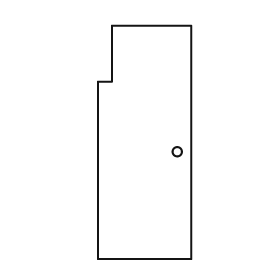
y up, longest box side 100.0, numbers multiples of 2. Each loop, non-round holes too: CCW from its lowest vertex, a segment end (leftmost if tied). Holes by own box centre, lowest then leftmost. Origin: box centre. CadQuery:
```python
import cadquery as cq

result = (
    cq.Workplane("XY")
    .moveTo(-20.0, -50.0)
    .lineTo(20.0, -50.0)
    .lineTo(20.0, 50.0)
    .lineTo(-14.0, 50.0)
    .lineTo(-14.0, 26.0)
    .lineTo(-20.0, 26.0)
    .close()
    .moveTo(14.0, -4.0)
    .circle(2.0)
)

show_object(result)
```